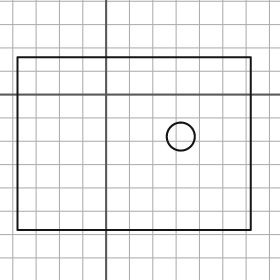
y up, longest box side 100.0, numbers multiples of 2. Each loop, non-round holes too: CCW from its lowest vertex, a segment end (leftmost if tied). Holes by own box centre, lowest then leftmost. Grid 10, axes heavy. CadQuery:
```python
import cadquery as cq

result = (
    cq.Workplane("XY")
    .moveTo(-38.0, -58.0)
    .lineTo(62.0, -58.0)
    .lineTo(62.0, 16.0)
    .lineTo(-38.0, 16.0)
    .close()
    .moveTo(32.0, -18.0)
    .circle(6.0)
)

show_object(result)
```